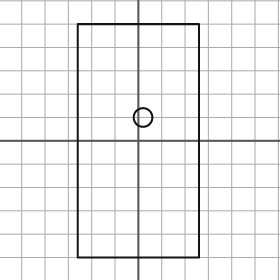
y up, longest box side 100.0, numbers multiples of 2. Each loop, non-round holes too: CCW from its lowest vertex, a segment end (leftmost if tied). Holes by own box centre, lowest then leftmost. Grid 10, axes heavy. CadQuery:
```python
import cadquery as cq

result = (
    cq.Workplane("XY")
    .moveTo(-26.0, -50.0)
    .lineTo(26.0, -50.0)
    .lineTo(26.0, 50.0)
    .lineTo(-26.0, 50.0)
    .close()
    .moveTo(2.0, 10.0)
    .circle(4.0)
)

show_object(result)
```